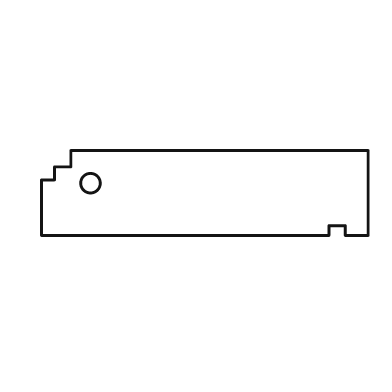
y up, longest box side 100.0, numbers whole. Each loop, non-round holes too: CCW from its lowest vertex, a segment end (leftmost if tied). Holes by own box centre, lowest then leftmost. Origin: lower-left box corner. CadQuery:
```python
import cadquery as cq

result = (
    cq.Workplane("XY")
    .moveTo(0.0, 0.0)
    .lineTo(88.0, 0.0)
    .lineTo(88.0, 3.0)
    .lineTo(93.0, 3.0)
    .lineTo(93.0, 0.0)
    .lineTo(100.0, 0.0)
    .lineTo(100.0, 26.0)
    .lineTo(9.0, 26.0)
    .lineTo(9.0, 21.0)
    .lineTo(4.0, 21.0)
    .lineTo(4.0, 17.0)
    .lineTo(0.0, 17.0)
    .close()
    .moveTo(15.0, 16.0)
    .circle(3.0)
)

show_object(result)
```